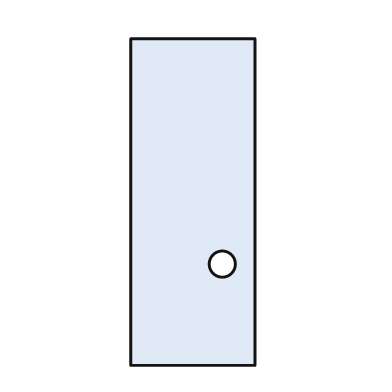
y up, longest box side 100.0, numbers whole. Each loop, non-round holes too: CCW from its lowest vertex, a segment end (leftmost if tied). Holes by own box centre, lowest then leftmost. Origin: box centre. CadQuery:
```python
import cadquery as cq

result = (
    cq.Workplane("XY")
    .moveTo(-19.0, -50.0)
    .lineTo(19.0, -50.0)
    .lineTo(19.0, 50.0)
    .lineTo(-19.0, 50.0)
    .close()
    .moveTo(9.0, -19.0)
    .circle(4.0)
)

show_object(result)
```